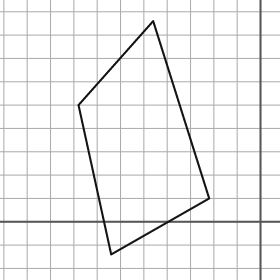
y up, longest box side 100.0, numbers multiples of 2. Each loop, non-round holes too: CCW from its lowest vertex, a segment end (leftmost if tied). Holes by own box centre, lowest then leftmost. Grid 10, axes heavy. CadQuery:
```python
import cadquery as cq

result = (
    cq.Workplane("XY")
    .moveTo(-64.0, -14.0)
    .lineTo(-22.0, 10.0)
    .lineTo(-46.0, 86.0)
    .lineTo(-78.0, 50.0)
    .close()
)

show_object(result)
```